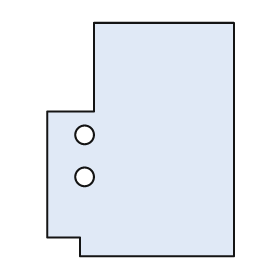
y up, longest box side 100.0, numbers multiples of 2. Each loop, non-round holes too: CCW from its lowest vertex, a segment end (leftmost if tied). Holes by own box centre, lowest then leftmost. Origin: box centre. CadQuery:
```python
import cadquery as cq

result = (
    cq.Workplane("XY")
    .moveTo(-26.0, -50.0)
    .lineTo(40.0, -50.0)
    .lineTo(40.0, 50.0)
    .lineTo(-20.0, 50.0)
    .lineTo(-20.0, 12.0)
    .lineTo(-40.0, 12.0)
    .lineTo(-40.0, -42.0)
    .lineTo(-26.0, -42.0)
    .close()
    .moveTo(-24.0, -16.0)
    .circle(4.0)
    .moveTo(-24.0, 2.0)
    .circle(4.0)
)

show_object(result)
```